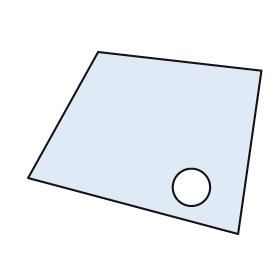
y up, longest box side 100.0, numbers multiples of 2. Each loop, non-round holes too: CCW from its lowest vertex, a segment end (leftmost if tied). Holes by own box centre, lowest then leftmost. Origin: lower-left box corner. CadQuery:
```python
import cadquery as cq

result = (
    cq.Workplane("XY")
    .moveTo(90.0, 0.0)
    .lineTo(100.0, 70.0)
    .lineTo(30.0, 78.0)
    .lineTo(0.0, 24.0)
    .close()
    .moveTo(70.0, 20.0)
    .circle(8.0)
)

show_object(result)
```